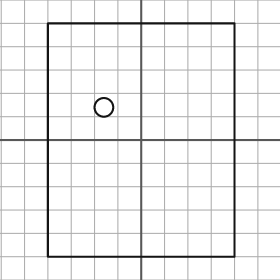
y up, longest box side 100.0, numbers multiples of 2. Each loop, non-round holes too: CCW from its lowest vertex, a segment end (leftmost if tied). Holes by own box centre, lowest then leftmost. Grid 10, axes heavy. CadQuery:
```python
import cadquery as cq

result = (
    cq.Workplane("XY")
    .moveTo(-40.0, -50.0)
    .lineTo(40.0, -50.0)
    .lineTo(40.0, 50.0)
    .lineTo(-40.0, 50.0)
    .close()
    .moveTo(-16.0, 14.0)
    .circle(4.0)
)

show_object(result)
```